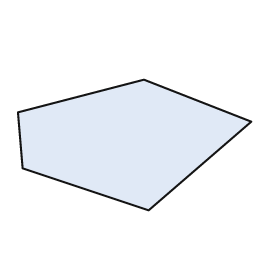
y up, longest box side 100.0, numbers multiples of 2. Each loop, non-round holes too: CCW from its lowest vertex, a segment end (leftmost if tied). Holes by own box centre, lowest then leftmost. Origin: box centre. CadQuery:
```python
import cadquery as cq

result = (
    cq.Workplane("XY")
    .moveTo(6.0, -28.0)
    .lineTo(50.0, 10.0)
    .lineTo(4.0, 28.0)
    .lineTo(-50.0, 14.0)
    .lineTo(-48.0, -10.0)
    .close()
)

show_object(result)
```